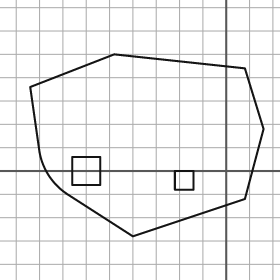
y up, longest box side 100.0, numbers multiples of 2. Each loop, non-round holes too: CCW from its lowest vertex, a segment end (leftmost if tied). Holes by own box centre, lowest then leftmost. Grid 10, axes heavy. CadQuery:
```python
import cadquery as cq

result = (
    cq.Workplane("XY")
    .moveTo(-40.0, -28.0)
    .lineTo(8.0, -12.0)
    .lineTo(16.0, 18.0)
    .lineTo(8.0, 44.0)
    .lineTo(-48.0, 50.0)
    .lineTo(-84.0, 36.0)
    .lineTo(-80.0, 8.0)
    .threePointArc((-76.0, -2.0), (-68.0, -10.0))
    .close()
    .moveTo(-22.0, -8.0)
    .lineTo(-14.0, -8.0)
    .lineTo(-14.0, 0.0)
    .lineTo(-22.0, 0.0)
    .close()
    .moveTo(-66.0, -6.0)
    .lineTo(-54.0, -6.0)
    .lineTo(-54.0, 6.0)
    .lineTo(-66.0, 6.0)
    .close()
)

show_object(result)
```